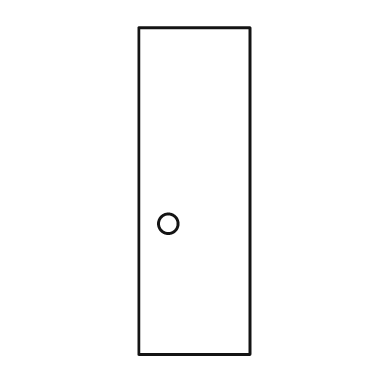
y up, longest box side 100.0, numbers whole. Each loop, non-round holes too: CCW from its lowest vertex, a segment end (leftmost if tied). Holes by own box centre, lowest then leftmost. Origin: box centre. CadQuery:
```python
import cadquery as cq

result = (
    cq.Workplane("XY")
    .moveTo(-17.0, -50.0)
    .lineTo(17.0, -50.0)
    .lineTo(17.0, 50.0)
    .lineTo(-17.0, 50.0)
    .close()
    .moveTo(-8.0, -10.0)
    .circle(3.0)
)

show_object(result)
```